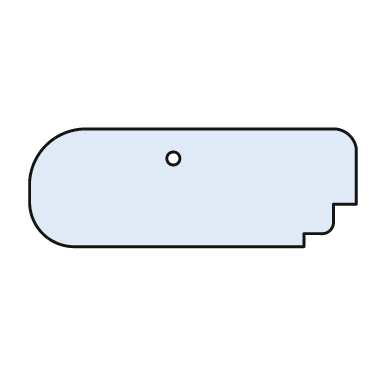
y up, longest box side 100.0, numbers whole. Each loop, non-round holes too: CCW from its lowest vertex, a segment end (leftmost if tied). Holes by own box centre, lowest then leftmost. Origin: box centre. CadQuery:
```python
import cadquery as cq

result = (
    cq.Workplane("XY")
    .moveTo(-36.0, -18.0)
    .lineTo(34.0, -18.0)
    .lineTo(34.0, -14.0)
    .lineTo(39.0, -14.0)
    .threePointArc((42.0, -13.0), (43.0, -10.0))
    .lineTo(43.0, -5.0)
    .lineTo(50.0, -5.0)
    .lineTo(50.0, 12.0)
    .threePointArc((48.0, 16.0), (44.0, 18.0))
    .lineTo(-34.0, 18.0)
    .threePointArc((-45.0, 13.0), (-50.0, 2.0))
    .lineTo(-50.0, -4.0)
    .threePointArc((-46.0, -14.0), (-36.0, -18.0))
    .close()
    .moveTo(-6.0, 9.0)
    .circle(2.0)
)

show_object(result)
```